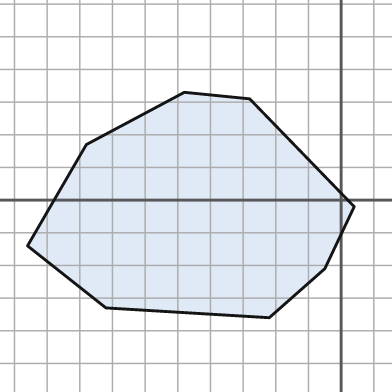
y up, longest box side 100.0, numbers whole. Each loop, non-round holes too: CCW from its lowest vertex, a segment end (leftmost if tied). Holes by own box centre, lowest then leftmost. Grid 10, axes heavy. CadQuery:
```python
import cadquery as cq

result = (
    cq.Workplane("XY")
    .moveTo(-22.0, -36.0)
    .lineTo(-5.0, -21.0)
    .lineTo(4.0, -2.0)
    .lineTo(-28.0, 31.0)
    .lineTo(-48.0, 33.0)
    .lineTo(-78.0, 17.0)
    .lineTo(-96.0, -14.0)
    .lineTo(-72.0, -33.0)
    .close()
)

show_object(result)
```